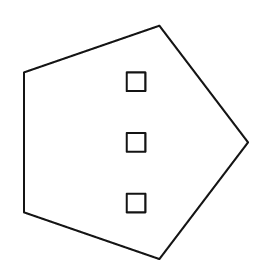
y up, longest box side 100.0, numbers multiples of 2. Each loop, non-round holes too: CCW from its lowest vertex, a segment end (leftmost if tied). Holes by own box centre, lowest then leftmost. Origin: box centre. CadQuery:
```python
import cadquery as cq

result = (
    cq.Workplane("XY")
    .moveTo(10.0, -50.0)
    .lineTo(48.0, 0.0)
    .lineTo(10.0, 50.0)
    .lineTo(-48.0, 30.0)
    .lineTo(-48.0, -30.0)
    .close()
    .moveTo(-4.0, -30.0)
    .lineTo(4.0, -30.0)
    .lineTo(4.0, -22.0)
    .lineTo(-4.0, -22.0)
    .close()
    .moveTo(-4.0, -4.0)
    .lineTo(4.0, -4.0)
    .lineTo(4.0, 4.0)
    .lineTo(-4.0, 4.0)
    .close()
    .moveTo(-4.0, 22.0)
    .lineTo(4.0, 22.0)
    .lineTo(4.0, 30.0)
    .lineTo(-4.0, 30.0)
    .close()
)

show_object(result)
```